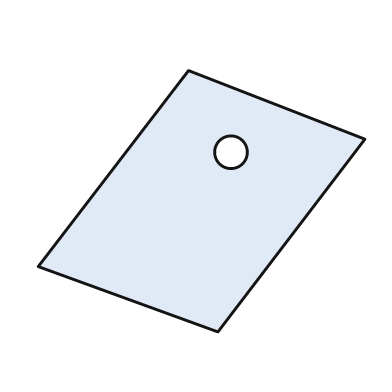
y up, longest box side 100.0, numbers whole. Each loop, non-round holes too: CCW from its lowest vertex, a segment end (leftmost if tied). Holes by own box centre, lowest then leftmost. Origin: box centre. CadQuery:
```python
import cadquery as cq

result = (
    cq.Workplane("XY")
    .moveTo(5.0, -40.0)
    .lineTo(50.0, 19.0)
    .lineTo(-4.0, 40.0)
    .lineTo(-50.0, -20.0)
    .close()
    .moveTo(9.0, 15.0)
    .circle(5.0)
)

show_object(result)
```